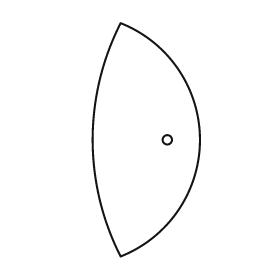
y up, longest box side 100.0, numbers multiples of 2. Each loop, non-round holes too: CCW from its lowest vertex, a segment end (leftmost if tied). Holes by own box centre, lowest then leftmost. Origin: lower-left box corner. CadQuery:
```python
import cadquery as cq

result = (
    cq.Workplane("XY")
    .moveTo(12.0, 0.0)
    .threePointArc((46.0, 50.0), (12.0, 100.0))
    .threePointArc((0.0, 50.0), (12.0, 0.0))
    .close()
    .moveTo(32.0, 50.0)
    .circle(2.0)
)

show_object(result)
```